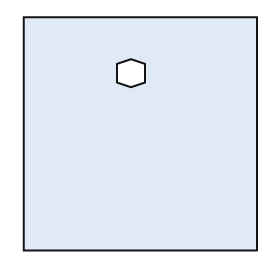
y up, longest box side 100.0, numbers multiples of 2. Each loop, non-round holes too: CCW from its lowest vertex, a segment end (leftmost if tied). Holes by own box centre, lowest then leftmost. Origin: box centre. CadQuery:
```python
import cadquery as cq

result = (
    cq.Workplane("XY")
    .moveTo(-50.0, -50.0)
    .lineTo(50.0, -50.0)
    .lineTo(50.0, 50.0)
    .lineTo(-50.0, 50.0)
    .close()
    .moveTo(-4.0, 20.0)
    .lineTo(2.0, 22.0)
    .lineTo(2.0, 30.0)
    .lineTo(-4.0, 32.0)
    .lineTo(-10.0, 30.0)
    .lineTo(-10.0, 22.0)
    .close()
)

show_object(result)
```